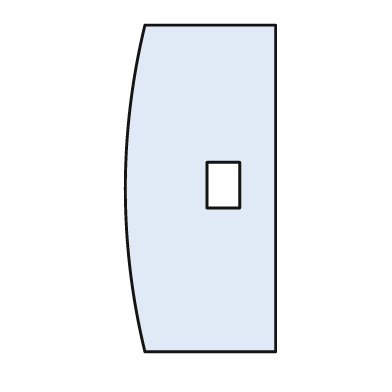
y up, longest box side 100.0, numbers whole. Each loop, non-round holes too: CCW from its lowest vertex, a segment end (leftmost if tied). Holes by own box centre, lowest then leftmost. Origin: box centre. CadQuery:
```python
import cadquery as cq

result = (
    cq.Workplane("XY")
    .moveTo(-17.0, -50.0)
    .lineTo(23.0, -50.0)
    .lineTo(23.0, 50.0)
    .lineTo(-17.0, 50.0)
    .threePointArc((-23.0, 0.0), (-17.0, -50.0))
    .close()
    .moveTo(2.0, -6.0)
    .lineTo(12.0, -6.0)
    .lineTo(12.0, 8.0)
    .lineTo(2.0, 8.0)
    .close()
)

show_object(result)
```